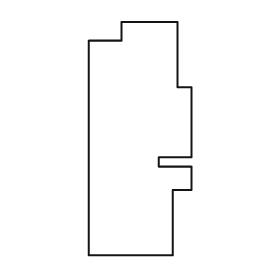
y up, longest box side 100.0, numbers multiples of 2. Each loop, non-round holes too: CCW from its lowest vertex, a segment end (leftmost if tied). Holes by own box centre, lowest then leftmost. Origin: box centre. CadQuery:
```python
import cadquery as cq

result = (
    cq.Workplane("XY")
    .moveTo(-22.0, -50.0)
    .lineTo(14.0, -50.0)
    .lineTo(14.0, -22.0)
    .lineTo(22.0, -22.0)
    .lineTo(22.0, -12.0)
    .lineTo(8.0, -12.0)
    .lineTo(8.0, -8.0)
    .lineTo(22.0, -8.0)
    .lineTo(22.0, 22.0)
    .lineTo(16.0, 22.0)
    .lineTo(16.0, 50.0)
    .lineTo(-8.0, 50.0)
    .lineTo(-8.0, 42.0)
    .lineTo(-22.0, 42.0)
    .close()
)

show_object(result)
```